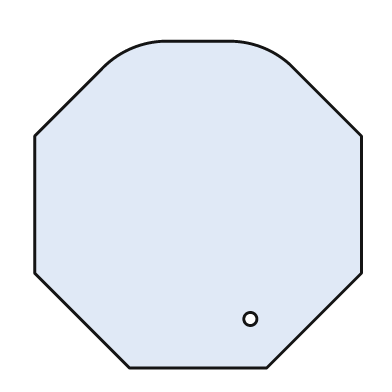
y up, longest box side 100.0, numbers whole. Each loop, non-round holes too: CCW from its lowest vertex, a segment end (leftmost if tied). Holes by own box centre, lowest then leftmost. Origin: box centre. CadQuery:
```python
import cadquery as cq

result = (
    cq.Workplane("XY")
    .moveTo(-21.0, -50.0)
    .lineTo(21.0, -50.0)
    .lineTo(50.0, -21.0)
    .lineTo(50.0, 21.0)
    .lineTo(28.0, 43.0)
    .threePointArc((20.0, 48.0), (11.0, 50.0))
    .lineTo(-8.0, 50.0)
    .threePointArc((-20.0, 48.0), (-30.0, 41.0))
    .lineTo(-50.0, 21.0)
    .lineTo(-50.0, -21.0)
    .close()
    .moveTo(16.0, -35.0)
    .circle(2.0)
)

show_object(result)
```